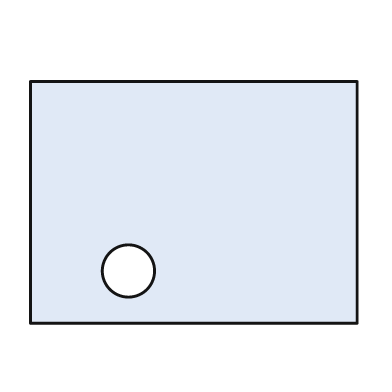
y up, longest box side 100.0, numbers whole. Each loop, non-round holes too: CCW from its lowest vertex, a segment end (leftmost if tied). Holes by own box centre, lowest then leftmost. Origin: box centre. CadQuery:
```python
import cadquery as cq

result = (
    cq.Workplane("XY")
    .moveTo(-50.0, -37.0)
    .lineTo(50.0, -37.0)
    .lineTo(50.0, 37.0)
    .lineTo(-50.0, 37.0)
    .close()
    .moveTo(-20.0, -21.0)
    .circle(8.0)
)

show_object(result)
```